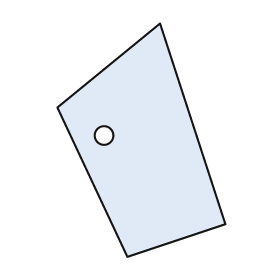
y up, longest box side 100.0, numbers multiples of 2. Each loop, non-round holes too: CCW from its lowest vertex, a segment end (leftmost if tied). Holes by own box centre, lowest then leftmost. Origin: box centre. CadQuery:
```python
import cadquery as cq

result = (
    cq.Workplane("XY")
    .moveTo(-6.0, -50.0)
    .lineTo(36.0, -36.0)
    .lineTo(8.0, 50.0)
    .lineTo(-36.0, 14.0)
    .close()
    .moveTo(-16.0, 2.0)
    .circle(4.0)
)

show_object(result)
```